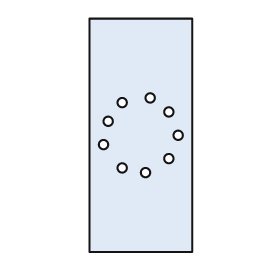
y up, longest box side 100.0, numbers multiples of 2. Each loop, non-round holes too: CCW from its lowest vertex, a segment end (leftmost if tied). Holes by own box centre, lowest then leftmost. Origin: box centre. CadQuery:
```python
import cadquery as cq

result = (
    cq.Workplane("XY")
    .moveTo(-22.0, -50.0)
    .lineTo(22.0, -50.0)
    .lineTo(22.0, 50.0)
    .lineTo(-22.0, 50.0)
    .close()
    .moveTo(2.0, -16.0)
    .circle(2.0)
    .moveTo(-8.0, -14.0)
    .circle(2.0)
    .moveTo(12.0, -10.0)
    .circle(2.0)
    .moveTo(-16.0, -4.0)
    .circle(2.0)
    .moveTo(16.0, 0.0)
    .circle(2.0)
    .moveTo(-14.0, 6.0)
    .circle(2.0)
    .moveTo(12.0, 10.0)
    .circle(2.0)
    .moveTo(-8.0, 14.0)
    .circle(2.0)
    .moveTo(4.0, 16.0)
    .circle(2.0)
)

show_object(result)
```